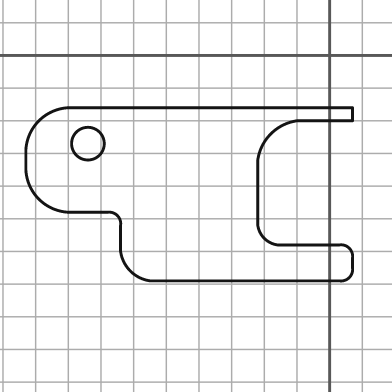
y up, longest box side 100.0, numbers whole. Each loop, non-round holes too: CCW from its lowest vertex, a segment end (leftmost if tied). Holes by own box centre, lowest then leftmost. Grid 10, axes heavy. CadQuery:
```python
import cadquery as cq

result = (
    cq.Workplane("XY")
    .moveTo(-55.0, -69.0)
    .lineTo(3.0, -69.0)
    .threePointArc((6.0, -68.0), (7.0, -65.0))
    .lineTo(7.0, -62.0)
    .threePointArc((6.0, -59.0), (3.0, -58.0))
    .lineTo(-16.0, -58.0)
    .threePointArc((-20.0, -56.0), (-22.0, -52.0))
    .lineTo(-22.0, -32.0)
    .threePointArc((-18.0, -24.0), (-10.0, -20.0))
    .lineTo(7.0, -20.0)
    .lineTo(7.0, -16.0)
    .lineTo(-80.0, -16.0)
    .threePointArc((-89.0, -20.0), (-93.0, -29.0))
    .lineTo(-93.0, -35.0)
    .threePointArc((-89.0, -44.0), (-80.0, -48.0))
    .lineTo(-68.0, -48.0)
    .threePointArc((-65.0, -49.0), (-64.0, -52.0))
    .lineTo(-64.0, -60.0)
    .threePointArc((-61.0, -66.0), (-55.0, -69.0))
    .close()
    .moveTo(-74.0, -27.0)
    .circle(5.0)
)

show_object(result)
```